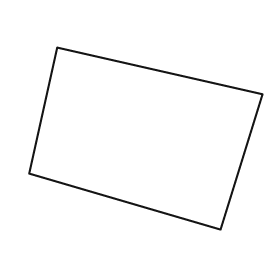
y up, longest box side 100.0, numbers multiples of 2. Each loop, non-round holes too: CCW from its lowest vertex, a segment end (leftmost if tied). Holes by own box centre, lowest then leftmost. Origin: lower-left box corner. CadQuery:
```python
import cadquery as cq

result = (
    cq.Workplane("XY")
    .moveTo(82.0, 0.0)
    .lineTo(100.0, 58.0)
    .lineTo(12.0, 78.0)
    .lineTo(0.0, 24.0)
    .close()
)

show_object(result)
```